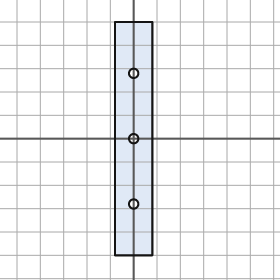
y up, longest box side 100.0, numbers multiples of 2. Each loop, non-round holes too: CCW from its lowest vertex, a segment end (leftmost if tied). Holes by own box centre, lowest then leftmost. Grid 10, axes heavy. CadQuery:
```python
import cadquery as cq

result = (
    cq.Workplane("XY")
    .moveTo(-8.0, -50.0)
    .lineTo(8.0, -50.0)
    .lineTo(8.0, 50.0)
    .lineTo(-8.0, 50.0)
    .close()
    .moveTo(0.0, -28.0)
    .circle(2.0)
    .moveTo(0.0, 0.0)
    .circle(2.0)
    .moveTo(0.0, 28.0)
    .circle(2.0)
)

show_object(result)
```